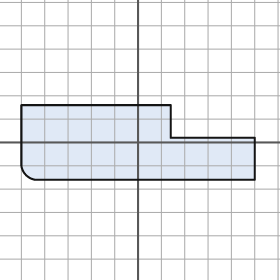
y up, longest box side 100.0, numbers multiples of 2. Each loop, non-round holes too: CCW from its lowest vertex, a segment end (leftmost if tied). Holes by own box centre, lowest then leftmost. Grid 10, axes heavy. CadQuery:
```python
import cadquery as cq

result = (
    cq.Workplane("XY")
    .moveTo(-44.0, -16.0)
    .lineTo(50.0, -16.0)
    .lineTo(50.0, 2.0)
    .lineTo(14.0, 2.0)
    .lineTo(14.0, 16.0)
    .lineTo(-50.0, 16.0)
    .lineTo(-50.0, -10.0)
    .threePointArc((-48.0, -14.0), (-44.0, -16.0))
    .close()
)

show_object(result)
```